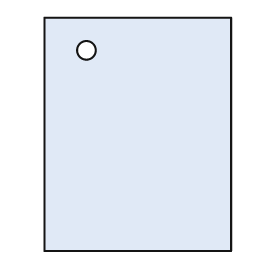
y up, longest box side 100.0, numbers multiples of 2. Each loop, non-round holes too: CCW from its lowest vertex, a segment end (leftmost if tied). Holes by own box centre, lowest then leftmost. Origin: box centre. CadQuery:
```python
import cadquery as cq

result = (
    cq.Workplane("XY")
    .moveTo(-40.0, -50.0)
    .lineTo(40.0, -50.0)
    .lineTo(40.0, 50.0)
    .lineTo(-40.0, 50.0)
    .close()
    .moveTo(-22.0, 36.0)
    .circle(4.0)
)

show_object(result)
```